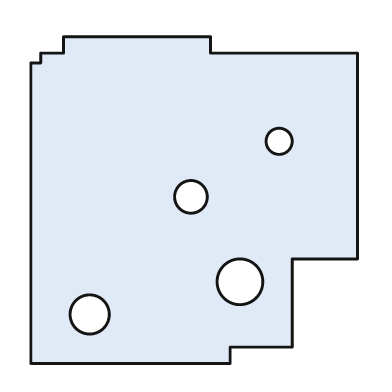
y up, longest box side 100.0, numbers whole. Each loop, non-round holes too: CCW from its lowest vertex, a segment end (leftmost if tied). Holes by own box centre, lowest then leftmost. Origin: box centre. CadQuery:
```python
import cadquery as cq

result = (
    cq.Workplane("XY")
    .moveTo(-50.0, -50.0)
    .lineTo(11.0, -50.0)
    .lineTo(11.0, -45.0)
    .lineTo(30.0, -45.0)
    .lineTo(30.0, -18.0)
    .lineTo(50.0, -18.0)
    .lineTo(50.0, 45.0)
    .lineTo(5.0, 45.0)
    .lineTo(5.0, 50.0)
    .lineTo(-40.0, 50.0)
    .lineTo(-40.0, 45.0)
    .lineTo(-47.0, 45.0)
    .lineTo(-47.0, 42.0)
    .lineTo(-50.0, 42.0)
    .close()
    .moveTo(-32.0, -35.0)
    .circle(6.0)
    .moveTo(14.0, -25.0)
    .circle(7.0)
    .moveTo(-1.0, 1.0)
    .circle(5.0)
    .moveTo(26.0, 18.0)
    .circle(4.0)
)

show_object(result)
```